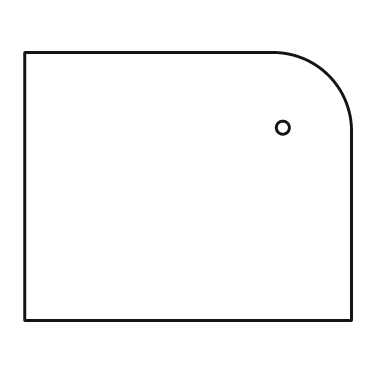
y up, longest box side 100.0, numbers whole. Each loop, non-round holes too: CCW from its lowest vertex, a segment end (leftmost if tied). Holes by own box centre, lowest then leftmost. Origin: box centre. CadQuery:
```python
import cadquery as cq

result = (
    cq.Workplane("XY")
    .moveTo(-50.0, -41.0)
    .lineTo(50.0, -41.0)
    .lineTo(50.0, 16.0)
    .threePointArc((43.0, 34.0), (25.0, 41.0))
    .lineTo(-50.0, 41.0)
    .close()
    .moveTo(29.0, 18.0)
    .circle(2.0)
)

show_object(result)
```